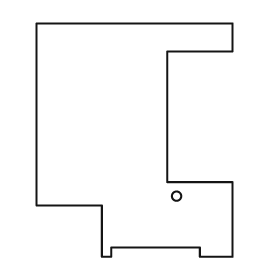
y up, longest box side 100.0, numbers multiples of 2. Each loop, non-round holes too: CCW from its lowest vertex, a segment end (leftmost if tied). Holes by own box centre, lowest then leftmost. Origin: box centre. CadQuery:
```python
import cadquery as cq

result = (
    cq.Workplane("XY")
    .moveTo(-14.0, -50.0)
    .lineTo(-10.0, -50.0)
    .lineTo(-10.0, -46.0)
    .lineTo(28.0, -46.0)
    .lineTo(28.0, -50.0)
    .lineTo(42.0, -50.0)
    .lineTo(42.0, -18.0)
    .lineTo(14.0, -18.0)
    .lineTo(14.0, 38.0)
    .lineTo(42.0, 38.0)
    .lineTo(42.0, 50.0)
    .lineTo(-42.0, 50.0)
    .lineTo(-42.0, -28.0)
    .lineTo(-14.0, -28.0)
    .close()
    .moveTo(18.0, -24.0)
    .circle(2.0)
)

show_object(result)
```